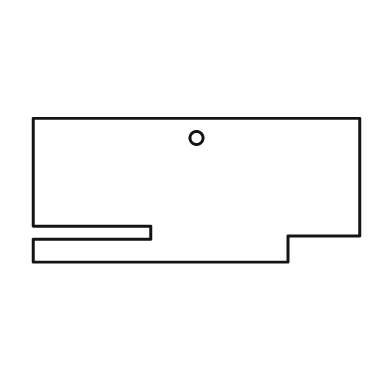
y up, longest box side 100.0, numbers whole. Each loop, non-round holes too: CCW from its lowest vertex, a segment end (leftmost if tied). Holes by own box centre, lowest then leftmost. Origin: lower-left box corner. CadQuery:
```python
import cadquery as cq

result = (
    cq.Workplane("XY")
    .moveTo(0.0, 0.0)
    .lineTo(78.0, 0.0)
    .lineTo(78.0, 8.0)
    .lineTo(100.0, 8.0)
    .lineTo(100.0, 44.0)
    .lineTo(0.0, 44.0)
    .lineTo(0.0, 11.0)
    .lineTo(36.0, 11.0)
    .lineTo(36.0, 7.0)
    .lineTo(0.0, 7.0)
    .close()
    .moveTo(50.0, 38.0)
    .circle(2.0)
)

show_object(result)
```